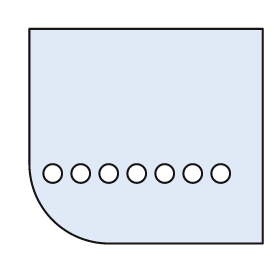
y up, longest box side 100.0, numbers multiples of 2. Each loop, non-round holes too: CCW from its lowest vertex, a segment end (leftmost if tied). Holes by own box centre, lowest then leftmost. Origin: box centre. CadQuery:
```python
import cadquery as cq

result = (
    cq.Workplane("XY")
    .moveTo(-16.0, -46.0)
    .lineTo(50.0, -46.0)
    .lineTo(50.0, 46.0)
    .lineTo(-50.0, 46.0)
    .lineTo(-50.0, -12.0)
    .threePointArc((-40.0, -36.0), (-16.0, -46.0))
    .close()
    .moveTo(-40.0, -16.0)
    .circle(4.0)
    .moveTo(-28.0, -16.0)
    .circle(4.0)
    .moveTo(-16.0, -16.0)
    .circle(4.0)
    .moveTo(-4.0, -16.0)
    .circle(4.0)
    .moveTo(8.0, -16.0)
    .circle(4.0)
    .moveTo(20.0, -16.0)
    .circle(4.0)
    .moveTo(32.0, -16.0)
    .circle(4.0)
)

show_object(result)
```